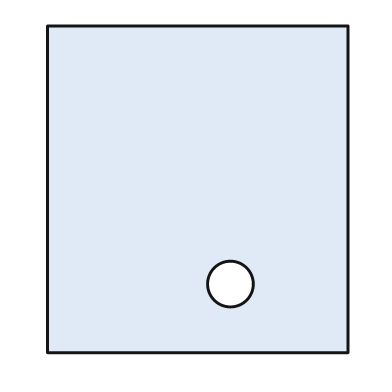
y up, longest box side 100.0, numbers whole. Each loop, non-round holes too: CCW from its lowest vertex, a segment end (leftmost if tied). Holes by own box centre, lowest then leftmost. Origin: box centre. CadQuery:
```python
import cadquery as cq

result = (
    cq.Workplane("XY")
    .moveTo(-46.0, -50.0)
    .lineTo(46.0, -50.0)
    .lineTo(46.0, 50.0)
    .lineTo(-46.0, 50.0)
    .close()
    .moveTo(10.0, -29.0)
    .circle(7.0)
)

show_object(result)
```